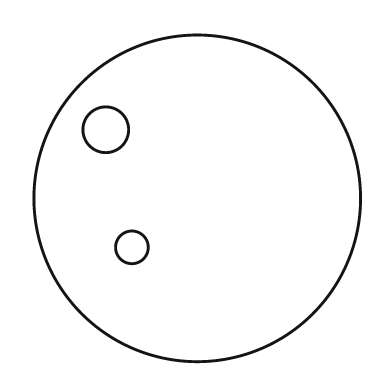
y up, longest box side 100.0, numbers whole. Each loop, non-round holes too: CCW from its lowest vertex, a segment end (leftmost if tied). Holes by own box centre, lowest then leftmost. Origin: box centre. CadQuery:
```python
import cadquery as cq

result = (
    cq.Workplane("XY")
    .moveTo(0.0, 0.0)
    .circle(50.0)
    .moveTo(-20.0, -15.0)
    .circle(5.0)
    .moveTo(-28.0, 21.0)
    .circle(7.0)
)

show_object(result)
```